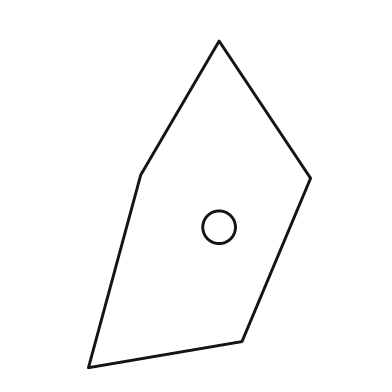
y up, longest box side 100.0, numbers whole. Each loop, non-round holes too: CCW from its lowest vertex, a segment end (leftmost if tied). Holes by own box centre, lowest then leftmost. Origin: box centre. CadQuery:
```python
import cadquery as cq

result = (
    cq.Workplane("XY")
    .moveTo(-34.0, -50.0)
    .lineTo(13.0, -42.0)
    .lineTo(34.0, 8.0)
    .lineTo(6.0, 50.0)
    .lineTo(-18.0, 9.0)
    .close()
    .moveTo(6.0, -7.0)
    .circle(5.0)
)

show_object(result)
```